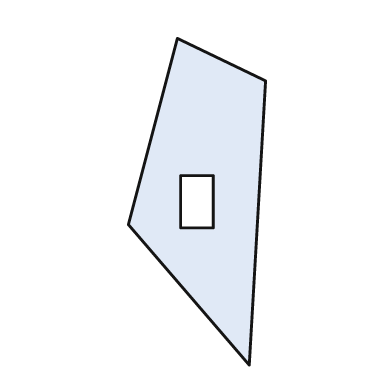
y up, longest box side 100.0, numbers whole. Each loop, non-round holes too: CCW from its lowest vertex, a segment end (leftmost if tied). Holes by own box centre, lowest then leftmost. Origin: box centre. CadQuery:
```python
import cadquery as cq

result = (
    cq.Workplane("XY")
    .moveTo(16.0, -50.0)
    .lineTo(21.0, 37.0)
    .lineTo(-6.0, 50.0)
    .lineTo(-21.0, -7.0)
    .close()
    .moveTo(-5.0, -8.0)
    .lineTo(5.0, -8.0)
    .lineTo(5.0, 8.0)
    .lineTo(-5.0, 8.0)
    .close()
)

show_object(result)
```